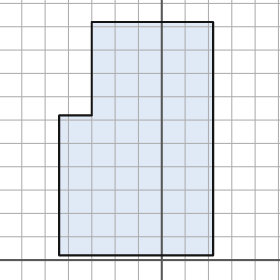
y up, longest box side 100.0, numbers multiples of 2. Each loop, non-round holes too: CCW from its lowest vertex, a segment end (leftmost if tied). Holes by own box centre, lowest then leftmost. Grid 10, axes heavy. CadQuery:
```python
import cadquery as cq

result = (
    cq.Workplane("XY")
    .moveTo(-44.0, 2.0)
    .lineTo(22.0, 2.0)
    .lineTo(22.0, 102.0)
    .lineTo(-30.0, 102.0)
    .lineTo(-30.0, 62.0)
    .lineTo(-44.0, 62.0)
    .close()
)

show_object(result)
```